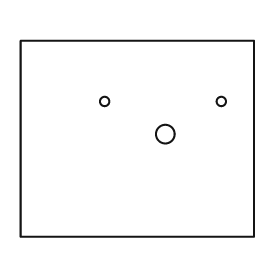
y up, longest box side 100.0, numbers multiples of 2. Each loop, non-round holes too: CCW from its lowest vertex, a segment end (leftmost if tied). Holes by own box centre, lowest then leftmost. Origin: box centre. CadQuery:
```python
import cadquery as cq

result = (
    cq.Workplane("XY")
    .moveTo(-50.0, -42.0)
    .lineTo(50.0, -42.0)
    .lineTo(50.0, 42.0)
    .lineTo(-50.0, 42.0)
    .close()
    .moveTo(12.0, 2.0)
    .circle(4.0)
    .moveTo(-14.0, 16.0)
    .circle(2.0)
    .moveTo(36.0, 16.0)
    .circle(2.0)
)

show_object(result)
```